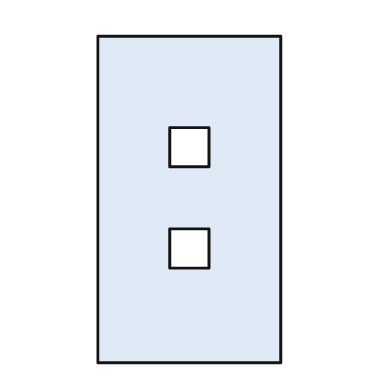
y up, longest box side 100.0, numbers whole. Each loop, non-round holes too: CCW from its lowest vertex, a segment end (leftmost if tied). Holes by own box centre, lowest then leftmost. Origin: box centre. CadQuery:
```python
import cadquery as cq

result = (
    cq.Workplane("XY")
    .moveTo(-28.0, -50.0)
    .lineTo(28.0, -50.0)
    .lineTo(28.0, 50.0)
    .lineTo(-28.0, 50.0)
    .close()
    .moveTo(-6.0, -21.0)
    .lineTo(6.0, -21.0)
    .lineTo(6.0, -9.0)
    .lineTo(-6.0, -9.0)
    .close()
    .moveTo(-6.0, 10.0)
    .lineTo(6.0, 10.0)
    .lineTo(6.0, 22.0)
    .lineTo(-6.0, 22.0)
    .close()
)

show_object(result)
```